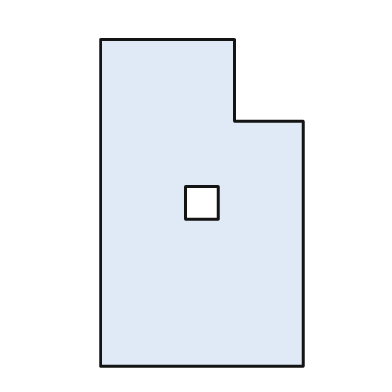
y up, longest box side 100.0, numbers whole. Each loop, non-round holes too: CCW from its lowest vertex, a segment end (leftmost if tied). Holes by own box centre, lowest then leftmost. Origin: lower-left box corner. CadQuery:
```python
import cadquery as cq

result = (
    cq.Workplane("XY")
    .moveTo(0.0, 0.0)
    .lineTo(62.0, 0.0)
    .lineTo(62.0, 75.0)
    .lineTo(41.0, 75.0)
    .lineTo(41.0, 100.0)
    .lineTo(0.0, 100.0)
    .close()
    .moveTo(26.0, 45.0)
    .lineTo(36.0, 45.0)
    .lineTo(36.0, 55.0)
    .lineTo(26.0, 55.0)
    .close()
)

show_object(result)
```